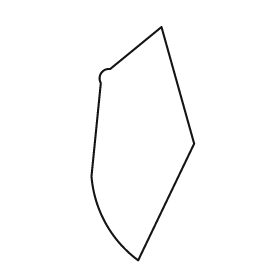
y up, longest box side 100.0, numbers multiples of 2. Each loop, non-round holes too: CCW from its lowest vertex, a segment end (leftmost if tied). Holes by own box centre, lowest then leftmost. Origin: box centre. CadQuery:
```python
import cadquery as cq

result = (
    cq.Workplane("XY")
    .moveTo(-2.0, -50.0)
    .lineTo(22.0, 0.0)
    .lineTo(8.0, 50.0)
    .lineTo(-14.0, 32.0)
    .threePointArc((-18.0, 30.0), (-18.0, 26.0))
    .lineTo(-22.0, -14.0)
    .threePointArc((-16.0, -34.0), (-2.0, -50.0))
    .close()
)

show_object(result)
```